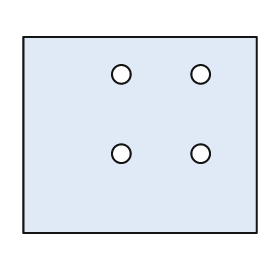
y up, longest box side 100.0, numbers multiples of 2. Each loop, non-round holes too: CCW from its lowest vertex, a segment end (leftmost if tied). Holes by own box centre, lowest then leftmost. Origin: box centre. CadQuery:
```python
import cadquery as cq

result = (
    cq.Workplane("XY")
    .moveTo(-50.0, -42.0)
    .lineTo(50.0, -42.0)
    .lineTo(50.0, 42.0)
    .lineTo(-50.0, 42.0)
    .close()
    .moveTo(-8.0, -8.0)
    .circle(4.0)
    .moveTo(26.0, -8.0)
    .circle(4.0)
    .moveTo(-8.0, 26.0)
    .circle(4.0)
    .moveTo(26.0, 26.0)
    .circle(4.0)
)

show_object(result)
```